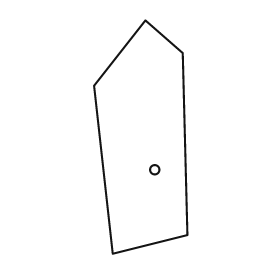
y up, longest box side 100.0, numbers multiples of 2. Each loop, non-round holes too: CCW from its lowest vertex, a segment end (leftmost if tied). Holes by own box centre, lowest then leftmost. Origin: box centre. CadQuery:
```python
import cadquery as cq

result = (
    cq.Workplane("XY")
    .moveTo(-12.0, -50.0)
    .lineTo(20.0, -42.0)
    .lineTo(18.0, 36.0)
    .lineTo(2.0, 50.0)
    .lineTo(-20.0, 22.0)
    .close()
    .moveTo(6.0, -14.0)
    .circle(2.0)
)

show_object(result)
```